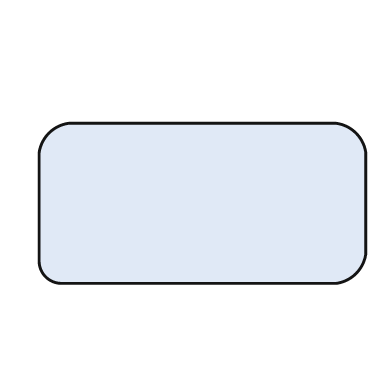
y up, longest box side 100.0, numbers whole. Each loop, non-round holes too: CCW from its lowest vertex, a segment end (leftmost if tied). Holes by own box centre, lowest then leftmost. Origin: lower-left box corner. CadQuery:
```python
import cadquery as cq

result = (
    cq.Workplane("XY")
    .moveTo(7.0, 0.0)
    .lineTo(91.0, 0.0)
    .threePointArc((97.0, 3.0), (100.0, 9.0))
    .lineTo(100.0, 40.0)
    .threePointArc((97.0, 46.0), (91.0, 49.0))
    .lineTo(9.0, 49.0)
    .threePointArc((3.0, 46.0), (0.0, 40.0))
    .lineTo(0.0, 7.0)
    .threePointArc((2.0, 2.0), (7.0, 0.0))
    .close()
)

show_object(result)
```